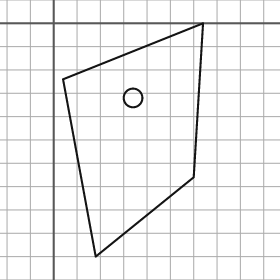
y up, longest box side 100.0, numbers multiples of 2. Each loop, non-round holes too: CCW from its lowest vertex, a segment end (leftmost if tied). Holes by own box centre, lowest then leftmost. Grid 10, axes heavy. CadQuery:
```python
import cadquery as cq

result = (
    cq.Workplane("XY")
    .moveTo(18.0, -100.0)
    .lineTo(60.0, -66.0)
    .lineTo(64.0, 0.0)
    .lineTo(4.0, -24.0)
    .close()
    .moveTo(34.0, -32.0)
    .circle(4.0)
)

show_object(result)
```